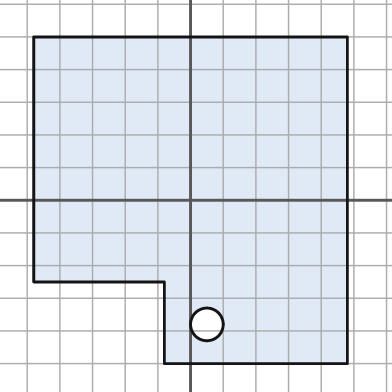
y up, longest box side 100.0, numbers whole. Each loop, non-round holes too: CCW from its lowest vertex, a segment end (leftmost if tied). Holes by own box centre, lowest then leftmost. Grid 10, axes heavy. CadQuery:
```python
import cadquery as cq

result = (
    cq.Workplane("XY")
    .moveTo(-8.0, -50.0)
    .lineTo(48.0, -50.0)
    .lineTo(48.0, 50.0)
    .lineTo(-48.0, 50.0)
    .lineTo(-48.0, -25.0)
    .lineTo(-8.0, -25.0)
    .close()
    .moveTo(5.0, -38.0)
    .circle(5.0)
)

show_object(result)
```